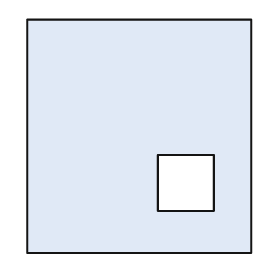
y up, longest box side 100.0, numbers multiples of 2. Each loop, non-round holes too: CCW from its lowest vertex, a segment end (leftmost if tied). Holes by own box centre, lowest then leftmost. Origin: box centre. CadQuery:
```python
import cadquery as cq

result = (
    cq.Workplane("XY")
    .moveTo(-48.0, -50.0)
    .lineTo(48.0, -50.0)
    .lineTo(48.0, 50.0)
    .lineTo(-48.0, 50.0)
    .close()
    .moveTo(8.0, -32.0)
    .lineTo(32.0, -32.0)
    .lineTo(32.0, -8.0)
    .lineTo(8.0, -8.0)
    .close()
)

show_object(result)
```